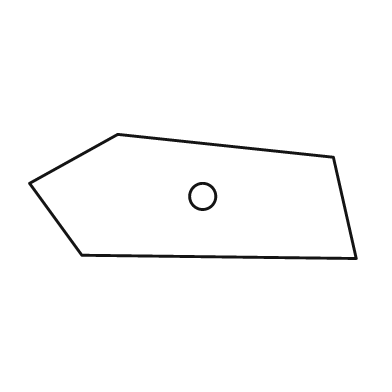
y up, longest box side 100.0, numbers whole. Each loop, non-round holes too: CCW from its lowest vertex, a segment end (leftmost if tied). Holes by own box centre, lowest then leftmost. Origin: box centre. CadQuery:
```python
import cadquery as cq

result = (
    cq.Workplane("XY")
    .moveTo(50.0, -19.0)
    .lineTo(43.0, 12.0)
    .lineTo(-23.0, 19.0)
    .lineTo(-50.0, 4.0)
    .lineTo(-34.0, -18.0)
    .close()
    .moveTo(3.0, 0.0)
    .circle(4.0)
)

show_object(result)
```